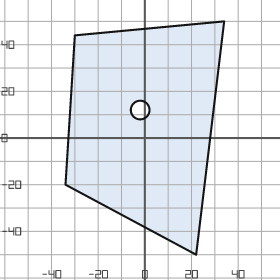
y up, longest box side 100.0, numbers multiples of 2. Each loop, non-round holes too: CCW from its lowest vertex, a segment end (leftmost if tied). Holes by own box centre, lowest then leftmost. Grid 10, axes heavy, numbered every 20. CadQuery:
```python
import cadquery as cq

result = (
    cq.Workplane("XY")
    .moveTo(22.0, -50.0)
    .lineTo(34.0, 50.0)
    .lineTo(-30.0, 44.0)
    .lineTo(-34.0, -20.0)
    .close()
    .moveTo(-2.0, 12.0)
    .circle(4.0)
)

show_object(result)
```